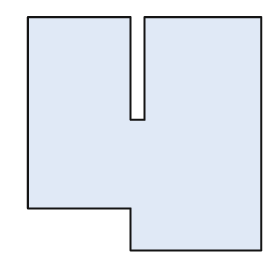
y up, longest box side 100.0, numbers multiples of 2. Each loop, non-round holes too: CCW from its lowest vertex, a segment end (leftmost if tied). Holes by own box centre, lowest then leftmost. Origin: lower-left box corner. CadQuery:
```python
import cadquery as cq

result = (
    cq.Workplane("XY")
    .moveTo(44.0, 0.0)
    .lineTo(100.0, 0.0)
    .lineTo(100.0, 100.0)
    .lineTo(50.0, 100.0)
    .lineTo(50.0, 56.0)
    .lineTo(44.0, 56.0)
    .lineTo(44.0, 100.0)
    .lineTo(0.0, 100.0)
    .lineTo(0.0, 18.0)
    .lineTo(44.0, 18.0)
    .close()
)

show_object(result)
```